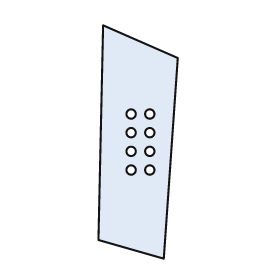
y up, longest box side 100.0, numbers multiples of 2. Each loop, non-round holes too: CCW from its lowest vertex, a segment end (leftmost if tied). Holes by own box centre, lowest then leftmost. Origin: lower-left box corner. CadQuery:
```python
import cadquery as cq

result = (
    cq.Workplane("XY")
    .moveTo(28.0, 0.0)
    .lineTo(34.0, 86.0)
    .lineTo(2.0, 100.0)
    .lineTo(0.0, 8.0)
    .close()
    .moveTo(14.0, 38.0)
    .circle(2.0)
    .moveTo(22.0, 38.0)
    .circle(2.0)
    .moveTo(14.0, 46.0)
    .circle(2.0)
    .moveTo(22.0, 46.0)
    .circle(2.0)
    .moveTo(14.0, 54.0)
    .circle(2.0)
    .moveTo(22.0, 54.0)
    .circle(2.0)
    .moveTo(14.0, 62.0)
    .circle(2.0)
    .moveTo(22.0, 62.0)
    .circle(2.0)
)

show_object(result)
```